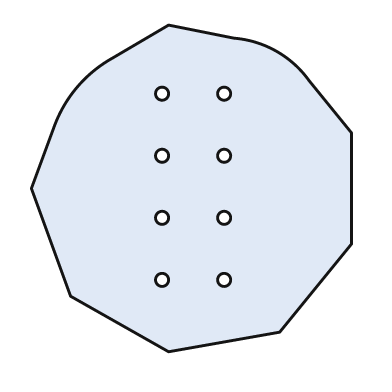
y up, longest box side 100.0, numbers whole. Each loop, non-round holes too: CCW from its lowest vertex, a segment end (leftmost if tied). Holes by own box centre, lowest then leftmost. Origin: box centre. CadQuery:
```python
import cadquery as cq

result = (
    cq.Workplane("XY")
    .moveTo(-7.0, -50.0)
    .lineTo(27.0, -44.0)
    .lineTo(49.0, -17.0)
    .lineTo(49.0, 17.0)
    .lineTo(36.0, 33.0)
    .threePointArc((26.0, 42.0), (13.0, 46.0))
    .lineTo(-7.0, 50.0)
    .lineTo(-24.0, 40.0)
    .threePointArc((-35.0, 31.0), (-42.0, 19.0))
    .lineTo(-49.0, 0.0)
    .lineTo(-37.0, -33.0)
    .close()
    .moveTo(-9.0, -28.0)
    .circle(2.0)
    .moveTo(10.0, -28.0)
    .circle(2.0)
    .moveTo(-9.0, -9.0)
    .circle(2.0)
    .moveTo(10.0, -9.0)
    .circle(2.0)
    .moveTo(-9.0, 10.0)
    .circle(2.0)
    .moveTo(10.0, 10.0)
    .circle(2.0)
    .moveTo(-9.0, 29.0)
    .circle(2.0)
    .moveTo(10.0, 29.0)
    .circle(2.0)
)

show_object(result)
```